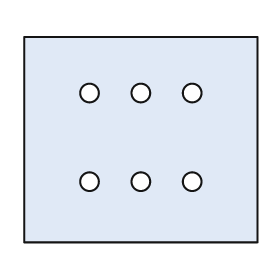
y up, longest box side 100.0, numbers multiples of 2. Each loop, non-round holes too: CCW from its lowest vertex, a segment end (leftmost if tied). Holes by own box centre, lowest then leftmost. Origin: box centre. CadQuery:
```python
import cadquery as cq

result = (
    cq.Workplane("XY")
    .moveTo(-50.0, -44.0)
    .lineTo(50.0, -44.0)
    .lineTo(50.0, 44.0)
    .lineTo(-50.0, 44.0)
    .close()
    .moveTo(-22.0, -18.0)
    .circle(4.0)
    .moveTo(0.0, -18.0)
    .circle(4.0)
    .moveTo(22.0, -18.0)
    .circle(4.0)
    .moveTo(-22.0, 20.0)
    .circle(4.0)
    .moveTo(0.0, 20.0)
    .circle(4.0)
    .moveTo(22.0, 20.0)
    .circle(4.0)
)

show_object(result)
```